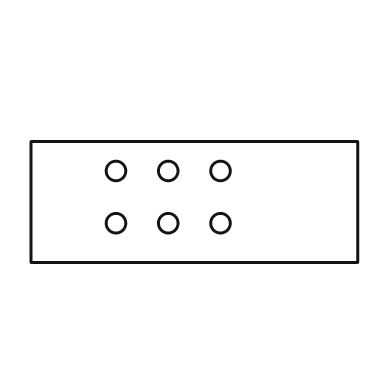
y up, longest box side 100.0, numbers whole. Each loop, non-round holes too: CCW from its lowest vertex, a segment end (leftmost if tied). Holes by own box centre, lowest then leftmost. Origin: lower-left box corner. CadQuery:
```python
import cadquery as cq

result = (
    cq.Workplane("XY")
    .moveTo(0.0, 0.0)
    .lineTo(100.0, 0.0)
    .lineTo(100.0, 37.0)
    .lineTo(0.0, 37.0)
    .close()
    .moveTo(26.0, 12.0)
    .circle(3.0)
    .moveTo(42.0, 12.0)
    .circle(3.0)
    .moveTo(58.0, 12.0)
    .circle(3.0)
    .moveTo(26.0, 28.0)
    .circle(3.0)
    .moveTo(42.0, 28.0)
    .circle(3.0)
    .moveTo(58.0, 28.0)
    .circle(3.0)
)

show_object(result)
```